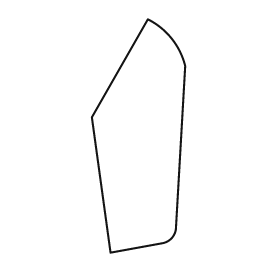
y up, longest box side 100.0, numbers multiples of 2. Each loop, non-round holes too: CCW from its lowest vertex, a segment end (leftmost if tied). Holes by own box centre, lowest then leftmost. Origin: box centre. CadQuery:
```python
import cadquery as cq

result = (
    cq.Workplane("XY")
    .moveTo(-12.0, -50.0)
    .lineTo(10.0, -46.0)
    .threePointArc((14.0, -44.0), (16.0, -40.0))
    .lineTo(20.0, 30.0)
    .threePointArc((14.0, 42.0), (4.0, 50.0))
    .lineTo(-20.0, 8.0)
    .close()
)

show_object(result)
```